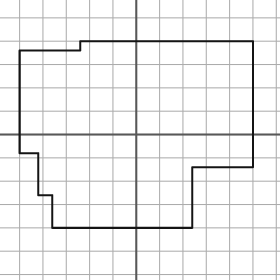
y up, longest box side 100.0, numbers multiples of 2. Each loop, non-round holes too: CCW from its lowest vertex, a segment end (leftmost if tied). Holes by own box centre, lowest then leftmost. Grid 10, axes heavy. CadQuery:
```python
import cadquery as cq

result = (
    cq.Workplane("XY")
    .moveTo(-36.0, -40.0)
    .lineTo(24.0, -40.0)
    .lineTo(24.0, -14.0)
    .lineTo(50.0, -14.0)
    .lineTo(50.0, 40.0)
    .lineTo(-24.0, 40.0)
    .lineTo(-24.0, 36.0)
    .lineTo(-50.0, 36.0)
    .lineTo(-50.0, -8.0)
    .lineTo(-42.0, -8.0)
    .lineTo(-42.0, -26.0)
    .lineTo(-36.0, -26.0)
    .close()
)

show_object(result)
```